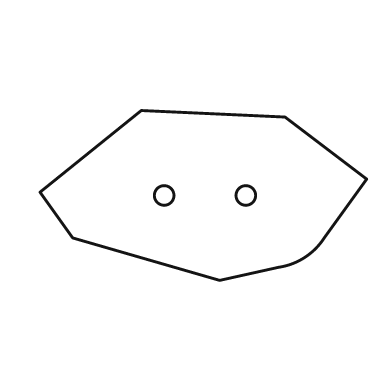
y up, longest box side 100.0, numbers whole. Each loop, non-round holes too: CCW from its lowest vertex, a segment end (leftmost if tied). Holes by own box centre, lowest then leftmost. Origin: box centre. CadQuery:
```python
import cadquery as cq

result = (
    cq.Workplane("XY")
    .moveTo(5.0, -26.0)
    .lineTo(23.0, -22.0)
    .threePointArc((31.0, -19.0), (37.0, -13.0))
    .lineTo(50.0, 5.0)
    .lineTo(25.0, 24.0)
    .lineTo(-19.0, 26.0)
    .lineTo(-50.0, 1.0)
    .lineTo(-40.0, -13.0)
    .close()
    .moveTo(-12.0, 0.0)
    .circle(3.0)
    .moveTo(13.0, 0.0)
    .circle(3.0)
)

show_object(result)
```